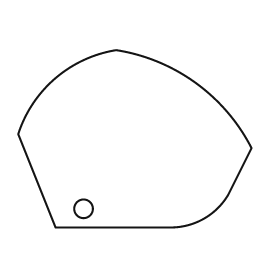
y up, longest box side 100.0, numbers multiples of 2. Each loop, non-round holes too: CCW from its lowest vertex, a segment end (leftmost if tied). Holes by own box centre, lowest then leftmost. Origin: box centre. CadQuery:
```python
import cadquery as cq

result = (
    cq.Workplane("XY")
    .moveTo(-34.0, -38.0)
    .lineTo(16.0, -38.0)
    .threePointArc((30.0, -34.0), (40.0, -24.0))
    .lineTo(50.0, -4.0)
    .threePointArc((26.0, 24.0), (-8.0, 38.0))
    .threePointArc((-34.0, 26.0), (-50.0, 2.0))
    .close()
    .moveTo(-22.0, -30.0)
    .circle(4.0)
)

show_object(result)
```